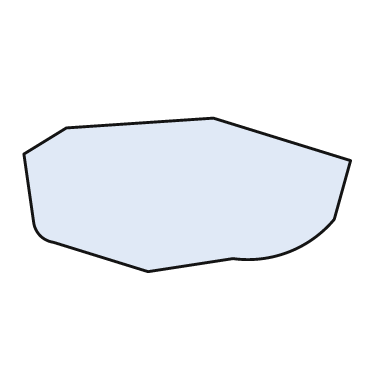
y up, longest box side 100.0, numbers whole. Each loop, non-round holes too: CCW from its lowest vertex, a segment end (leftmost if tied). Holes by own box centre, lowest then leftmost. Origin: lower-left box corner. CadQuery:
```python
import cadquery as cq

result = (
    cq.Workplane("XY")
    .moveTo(38.0, 0.0)
    .lineTo(64.0, 4.0)
    .threePointArc((81.0, 6.0), (95.0, 16.0))
    .lineTo(100.0, 34.0)
    .lineTo(58.0, 47.0)
    .lineTo(13.0, 44.0)
    .lineTo(0.0, 36.0)
    .lineTo(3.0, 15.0)
    .threePointArc((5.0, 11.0), (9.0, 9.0))
    .close()
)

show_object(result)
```